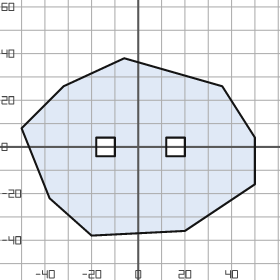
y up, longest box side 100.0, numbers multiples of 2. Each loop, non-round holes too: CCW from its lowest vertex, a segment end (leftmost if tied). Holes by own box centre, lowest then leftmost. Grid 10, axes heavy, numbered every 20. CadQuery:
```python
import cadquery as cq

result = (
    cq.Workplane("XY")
    .moveTo(-20.0, -38.0)
    .lineTo(20.0, -36.0)
    .lineTo(50.0, -16.0)
    .lineTo(50.0, 4.0)
    .lineTo(36.0, 26.0)
    .lineTo(-6.0, 38.0)
    .lineTo(-32.0, 26.0)
    .lineTo(-50.0, 8.0)
    .lineTo(-38.0, -22.0)
    .close()
    .moveTo(-18.0, -4.0)
    .lineTo(-10.0, -4.0)
    .lineTo(-10.0, 4.0)
    .lineTo(-18.0, 4.0)
    .close()
    .moveTo(12.0, -4.0)
    .lineTo(20.0, -4.0)
    .lineTo(20.0, 4.0)
    .lineTo(12.0, 4.0)
    .close()
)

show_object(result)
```